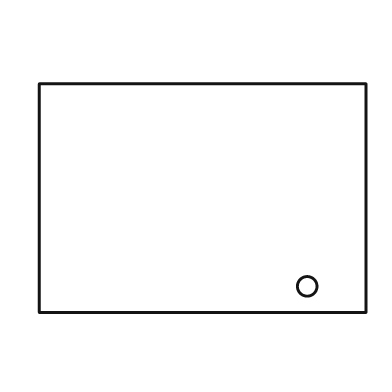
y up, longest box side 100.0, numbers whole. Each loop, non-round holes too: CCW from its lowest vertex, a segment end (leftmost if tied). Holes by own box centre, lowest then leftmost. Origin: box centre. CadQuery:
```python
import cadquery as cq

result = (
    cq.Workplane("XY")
    .moveTo(-50.0, -35.0)
    .lineTo(50.0, -35.0)
    .lineTo(50.0, 35.0)
    .lineTo(-50.0, 35.0)
    .close()
    .moveTo(32.0, -27.0)
    .circle(3.0)
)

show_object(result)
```